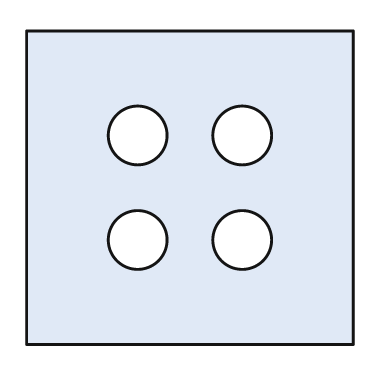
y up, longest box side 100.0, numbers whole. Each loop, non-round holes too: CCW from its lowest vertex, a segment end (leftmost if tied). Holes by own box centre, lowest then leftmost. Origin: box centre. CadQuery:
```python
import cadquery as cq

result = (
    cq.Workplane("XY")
    .moveTo(-50.0, -48.0)
    .lineTo(50.0, -48.0)
    .lineTo(50.0, 48.0)
    .lineTo(-50.0, 48.0)
    .close()
    .moveTo(-16.0, -16.0)
    .circle(9.0)
    .moveTo(16.0, -16.0)
    .circle(9.0)
    .moveTo(-16.0, 16.0)
    .circle(9.0)
    .moveTo(16.0, 16.0)
    .circle(9.0)
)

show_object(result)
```